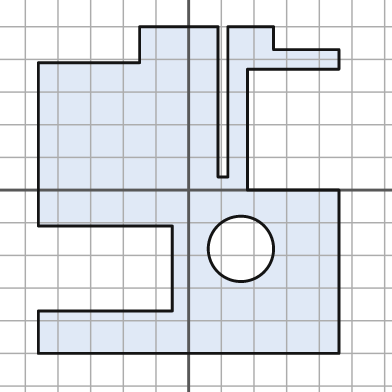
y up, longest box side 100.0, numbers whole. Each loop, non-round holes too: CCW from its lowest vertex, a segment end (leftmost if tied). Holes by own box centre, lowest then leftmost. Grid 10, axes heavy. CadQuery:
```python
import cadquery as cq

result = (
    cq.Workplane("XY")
    .moveTo(-46.0, -50.0)
    .lineTo(46.0, -50.0)
    .lineTo(46.0, 0.0)
    .lineTo(18.0, 0.0)
    .lineTo(18.0, 37.0)
    .lineTo(46.0, 37.0)
    .lineTo(46.0, 43.0)
    .lineTo(26.0, 43.0)
    .lineTo(26.0, 50.0)
    .lineTo(12.0, 50.0)
    .lineTo(12.0, 4.0)
    .lineTo(9.0, 4.0)
    .lineTo(9.0, 50.0)
    .lineTo(-15.0, 50.0)
    .lineTo(-15.0, 39.0)
    .lineTo(-46.0, 39.0)
    .lineTo(-46.0, -11.0)
    .lineTo(-5.0, -11.0)
    .lineTo(-5.0, -37.0)
    .lineTo(-46.0, -37.0)
    .close()
    .moveTo(16.0, -18.0)
    .circle(10.0)
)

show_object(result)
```